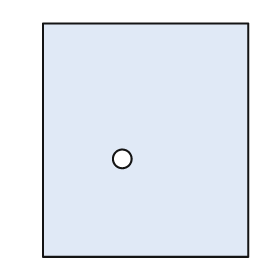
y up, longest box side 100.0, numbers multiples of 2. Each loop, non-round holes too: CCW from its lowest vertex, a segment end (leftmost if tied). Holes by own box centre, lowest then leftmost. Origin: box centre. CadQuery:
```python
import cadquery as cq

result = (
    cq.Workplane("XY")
    .moveTo(-44.0, -50.0)
    .lineTo(44.0, -50.0)
    .lineTo(44.0, 50.0)
    .lineTo(-44.0, 50.0)
    .close()
    .moveTo(-10.0, -8.0)
    .circle(4.0)
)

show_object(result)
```